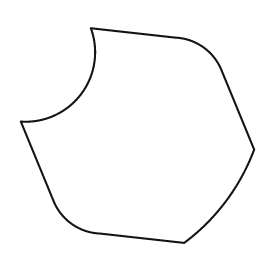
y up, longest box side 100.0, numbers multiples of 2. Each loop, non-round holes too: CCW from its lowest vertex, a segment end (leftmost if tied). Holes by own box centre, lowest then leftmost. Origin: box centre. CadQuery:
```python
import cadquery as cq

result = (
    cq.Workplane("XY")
    .moveTo(20.0, -46.0)
    .threePointArc((38.0, -28.0), (50.0, -6.0))
    .lineTo(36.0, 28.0)
    .threePointArc((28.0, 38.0), (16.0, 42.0))
    .lineTo(-20.0, 46.0)
    .threePointArc((-24.0, 18.0), (-50.0, 6.0))
    .lineTo(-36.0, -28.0)
    .threePointArc((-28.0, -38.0), (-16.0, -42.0))
    .close()
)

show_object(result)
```